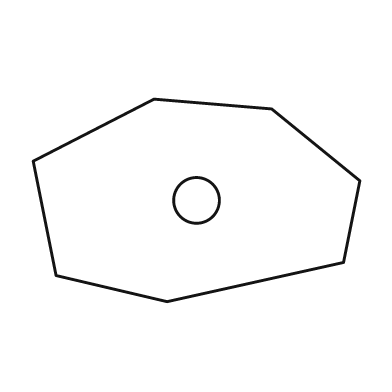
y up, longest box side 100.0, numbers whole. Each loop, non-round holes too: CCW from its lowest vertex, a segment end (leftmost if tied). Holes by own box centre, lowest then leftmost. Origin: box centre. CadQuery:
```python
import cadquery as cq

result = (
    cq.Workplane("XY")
    .moveTo(-9.0, -31.0)
    .lineTo(45.0, -19.0)
    .lineTo(50.0, 6.0)
    .lineTo(23.0, 28.0)
    .lineTo(-13.0, 31.0)
    .lineTo(-50.0, 12.0)
    .lineTo(-43.0, -23.0)
    .close()
    .moveTo(0.0, 0.0)
    .circle(7.0)
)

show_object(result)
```